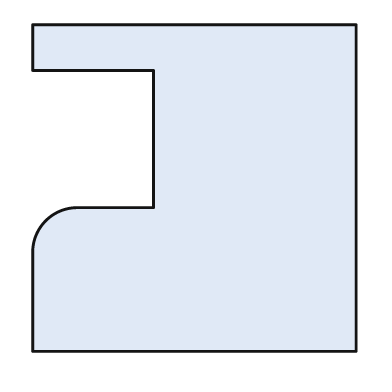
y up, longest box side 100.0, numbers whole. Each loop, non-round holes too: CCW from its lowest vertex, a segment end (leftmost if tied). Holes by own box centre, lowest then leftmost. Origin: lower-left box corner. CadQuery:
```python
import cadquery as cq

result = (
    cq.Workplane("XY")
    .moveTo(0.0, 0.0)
    .lineTo(99.0, 0.0)
    .lineTo(99.0, 100.0)
    .lineTo(0.0, 100.0)
    .lineTo(0.0, 86.0)
    .lineTo(37.0, 86.0)
    .lineTo(37.0, 44.0)
    .lineTo(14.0, 44.0)
    .threePointArc((4.0, 40.0), (0.0, 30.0))
    .close()
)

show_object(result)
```